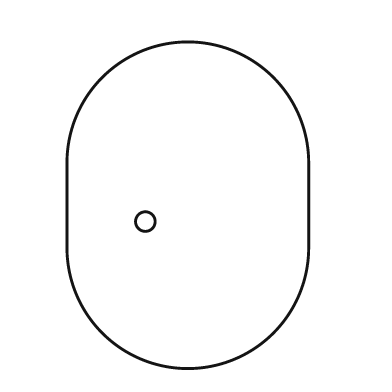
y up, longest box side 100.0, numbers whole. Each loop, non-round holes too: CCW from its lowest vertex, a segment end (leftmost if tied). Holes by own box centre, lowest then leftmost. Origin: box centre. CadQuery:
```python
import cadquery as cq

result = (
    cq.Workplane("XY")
    .moveTo(-37.0, -13.0)
    .threePointArc((0.0, -50.0), (37.0, -13.0))
    .lineTo(37.0, 13.0)
    .threePointArc((0.0, 50.0), (-37.0, 13.0))
    .close()
    .moveTo(-13.0, -5.0)
    .circle(3.0)
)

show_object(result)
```